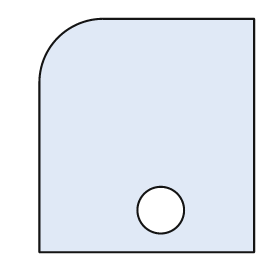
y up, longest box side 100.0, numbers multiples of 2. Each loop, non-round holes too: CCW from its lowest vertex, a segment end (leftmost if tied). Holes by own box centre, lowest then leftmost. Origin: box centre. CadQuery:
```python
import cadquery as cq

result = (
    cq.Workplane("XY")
    .moveTo(-46.0, -50.0)
    .lineTo(46.0, -50.0)
    .lineTo(46.0, 50.0)
    .lineTo(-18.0, 50.0)
    .threePointArc((-38.0, 42.0), (-46.0, 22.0))
    .close()
    .moveTo(6.0, -32.0)
    .circle(10.0)
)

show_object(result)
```